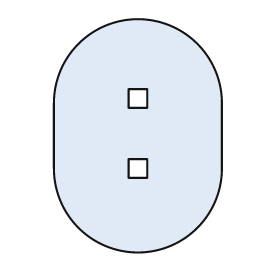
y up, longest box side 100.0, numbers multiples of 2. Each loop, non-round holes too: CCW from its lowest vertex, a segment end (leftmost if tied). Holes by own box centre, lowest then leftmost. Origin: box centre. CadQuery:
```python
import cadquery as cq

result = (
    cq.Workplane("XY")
    .moveTo(-36.0, -14.0)
    .threePointArc((0.0, -50.0), (36.0, -14.0))
    .lineTo(36.0, 14.0)
    .threePointArc((0.0, 50.0), (-36.0, 14.0))
    .close()
    .moveTo(-4.0, -18.0)
    .lineTo(4.0, -18.0)
    .lineTo(4.0, -10.0)
    .lineTo(-4.0, -10.0)
    .close()
    .moveTo(-4.0, 12.0)
    .lineTo(4.0, 12.0)
    .lineTo(4.0, 20.0)
    .lineTo(-4.0, 20.0)
    .close()
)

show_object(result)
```